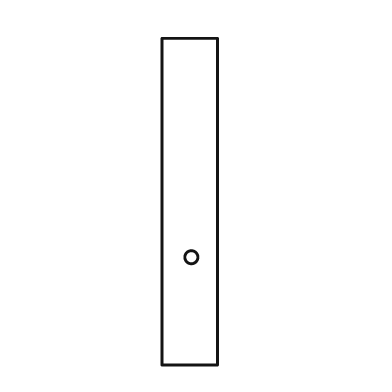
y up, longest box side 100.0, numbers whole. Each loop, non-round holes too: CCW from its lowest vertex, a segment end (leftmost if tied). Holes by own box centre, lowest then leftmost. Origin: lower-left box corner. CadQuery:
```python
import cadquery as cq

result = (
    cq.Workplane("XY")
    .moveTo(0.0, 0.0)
    .lineTo(17.0, 0.0)
    .lineTo(17.0, 100.0)
    .lineTo(0.0, 100.0)
    .close()
    .moveTo(9.0, 33.0)
    .circle(2.0)
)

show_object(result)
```